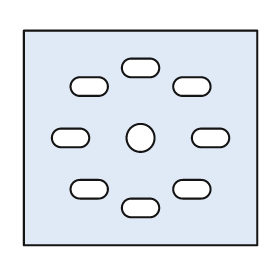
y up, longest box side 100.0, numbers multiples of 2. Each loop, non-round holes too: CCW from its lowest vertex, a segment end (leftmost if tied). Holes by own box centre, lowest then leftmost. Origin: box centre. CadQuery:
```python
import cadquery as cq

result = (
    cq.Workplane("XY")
    .moveTo(-50.0, -46.0)
    .lineTo(50.0, -46.0)
    .lineTo(50.0, 46.0)
    .lineTo(-50.0, 46.0)
    .close()
    .moveTo(-4.0, -34.0)
    .lineTo(4.0, -34.0)
    .threePointArc((8.0, -30.0), (4.0, -26.0))
    .lineTo(-4.0, -26.0)
    .threePointArc((-8.0, -30.0), (-4.0, -34.0))
    .close()
    .moveTo(-26.0, -26.0)
    .lineTo(-18.0, -26.0)
    .threePointArc((-14.0, -22.0), (-18.0, -18.0))
    .lineTo(-26.0, -18.0)
    .threePointArc((-30.0, -22.0), (-26.0, -26.0))
    .close()
    .moveTo(18.0, -26.0)
    .lineTo(26.0, -26.0)
    .threePointArc((30.0, -22.0), (26.0, -18.0))
    .lineTo(18.0, -18.0)
    .threePointArc((14.0, -22.0), (18.0, -26.0))
    .close()
    .moveTo(-34.0, -4.0)
    .lineTo(-26.0, -4.0)
    .threePointArc((-22.0, 0.0), (-26.0, 4.0))
    .lineTo(-34.0, 4.0)
    .threePointArc((-38.0, 0.0), (-34.0, -4.0))
    .close()
    .moveTo(0.0, 0.0)
    .circle(6.0)
    .moveTo(26.0, -4.0)
    .lineTo(34.0, -4.0)
    .threePointArc((38.0, 0.0), (34.0, 4.0))
    .lineTo(26.0, 4.0)
    .threePointArc((22.0, 0.0), (26.0, -4.0))
    .close()
    .moveTo(-26.0, 18.0)
    .lineTo(-18.0, 18.0)
    .threePointArc((-14.0, 22.0), (-18.0, 26.0))
    .lineTo(-26.0, 26.0)
    .threePointArc((-30.0, 22.0), (-26.0, 18.0))
    .close()
    .moveTo(18.0, 18.0)
    .lineTo(26.0, 18.0)
    .threePointArc((30.0, 22.0), (26.0, 26.0))
    .lineTo(18.0, 26.0)
    .threePointArc((14.0, 22.0), (18.0, 18.0))
    .close()
    .moveTo(-4.0, 26.0)
    .lineTo(4.0, 26.0)
    .threePointArc((8.0, 30.0), (4.0, 34.0))
    .lineTo(-4.0, 34.0)
    .threePointArc((-8.0, 30.0), (-4.0, 26.0))
    .close()
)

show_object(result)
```